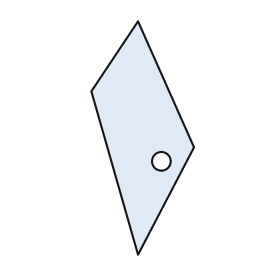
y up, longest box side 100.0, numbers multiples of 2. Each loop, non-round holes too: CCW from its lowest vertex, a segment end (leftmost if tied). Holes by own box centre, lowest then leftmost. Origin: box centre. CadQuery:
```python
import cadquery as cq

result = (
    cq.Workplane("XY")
    .moveTo(-2.0, -50.0)
    .lineTo(22.0, -4.0)
    .lineTo(-2.0, 50.0)
    .lineTo(-22.0, 20.0)
    .close()
    .moveTo(8.0, -10.0)
    .circle(4.0)
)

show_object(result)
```